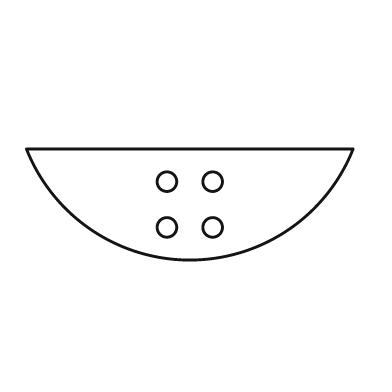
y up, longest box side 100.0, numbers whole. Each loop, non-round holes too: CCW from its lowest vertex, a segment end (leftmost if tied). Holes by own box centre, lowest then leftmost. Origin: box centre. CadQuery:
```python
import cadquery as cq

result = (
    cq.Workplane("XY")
    .moveTo(-50.0, 17.0)
    .threePointArc((0.0, -17.0), (50.0, 17.0))
    .close()
    .moveTo(-7.0, -7.0)
    .circle(3.0)
    .moveTo(7.0, -7.0)
    .circle(3.0)
    .moveTo(-7.0, 7.0)
    .circle(3.0)
    .moveTo(7.0, 7.0)
    .circle(3.0)
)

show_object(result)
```